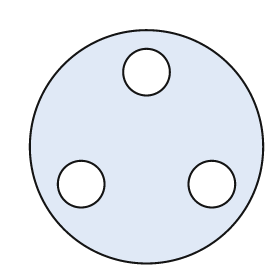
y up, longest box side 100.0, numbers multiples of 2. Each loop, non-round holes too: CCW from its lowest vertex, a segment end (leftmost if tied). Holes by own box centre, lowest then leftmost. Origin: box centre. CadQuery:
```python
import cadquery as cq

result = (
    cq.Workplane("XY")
    .moveTo(0.0, 0.0)
    .circle(50.0)
    .moveTo(-28.0, -16.0)
    .circle(10.0)
    .moveTo(28.0, -16.0)
    .circle(10.0)
    .moveTo(0.0, 32.0)
    .circle(10.0)
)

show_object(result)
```